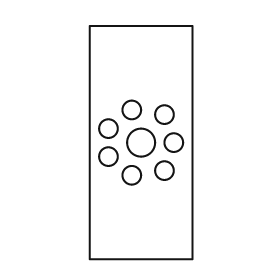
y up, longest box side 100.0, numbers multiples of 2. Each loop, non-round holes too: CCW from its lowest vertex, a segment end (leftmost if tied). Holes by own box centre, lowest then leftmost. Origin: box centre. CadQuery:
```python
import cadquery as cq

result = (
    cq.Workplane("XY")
    .moveTo(-22.0, -50.0)
    .lineTo(22.0, -50.0)
    .lineTo(22.0, 50.0)
    .lineTo(-22.0, 50.0)
    .close()
    .moveTo(-4.0, -14.0)
    .circle(4.0)
    .moveTo(10.0, -12.0)
    .circle(4.0)
    .moveTo(-14.0, -6.0)
    .circle(4.0)
    .moveTo(0.0, 0.0)
    .circle(6.0)
    .moveTo(14.0, 0.0)
    .circle(4.0)
    .moveTo(-14.0, 6.0)
    .circle(4.0)
    .moveTo(10.0, 12.0)
    .circle(4.0)
    .moveTo(-4.0, 14.0)
    .circle(4.0)
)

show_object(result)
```